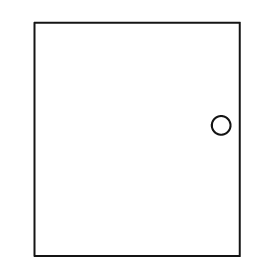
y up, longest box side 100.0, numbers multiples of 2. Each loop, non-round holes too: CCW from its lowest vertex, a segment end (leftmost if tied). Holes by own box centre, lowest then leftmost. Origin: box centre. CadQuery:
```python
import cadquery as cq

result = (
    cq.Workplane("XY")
    .moveTo(-44.0, -50.0)
    .lineTo(44.0, -50.0)
    .lineTo(44.0, 50.0)
    .lineTo(-44.0, 50.0)
    .close()
    .moveTo(36.0, 6.0)
    .circle(4.0)
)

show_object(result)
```